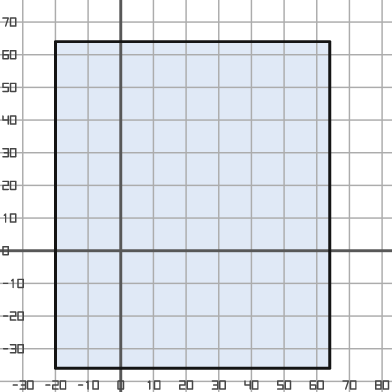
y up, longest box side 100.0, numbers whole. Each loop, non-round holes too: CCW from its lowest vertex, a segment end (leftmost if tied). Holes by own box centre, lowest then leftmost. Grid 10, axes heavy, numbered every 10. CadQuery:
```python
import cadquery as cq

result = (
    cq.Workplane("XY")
    .moveTo(-20.0, -36.0)
    .lineTo(64.0, -36.0)
    .lineTo(64.0, 64.0)
    .lineTo(-20.0, 64.0)
    .close()
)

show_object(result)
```